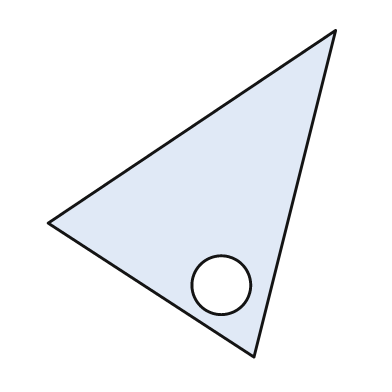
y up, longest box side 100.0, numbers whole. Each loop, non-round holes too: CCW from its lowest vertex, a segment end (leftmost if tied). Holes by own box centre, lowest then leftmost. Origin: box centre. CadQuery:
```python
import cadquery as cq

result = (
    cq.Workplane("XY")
    .moveTo(19.0, -50.0)
    .lineTo(44.0, 50.0)
    .lineTo(-44.0, -9.0)
    .close()
    .moveTo(9.0, -28.0)
    .circle(9.0)
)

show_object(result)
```